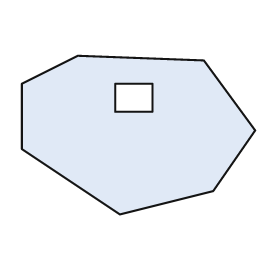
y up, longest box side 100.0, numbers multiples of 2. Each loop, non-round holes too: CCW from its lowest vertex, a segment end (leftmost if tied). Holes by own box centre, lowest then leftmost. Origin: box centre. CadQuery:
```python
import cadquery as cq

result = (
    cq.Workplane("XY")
    .moveTo(-8.0, -34.0)
    .lineTo(32.0, -24.0)
    .lineTo(50.0, 2.0)
    .lineTo(28.0, 32.0)
    .lineTo(-26.0, 34.0)
    .lineTo(-50.0, 22.0)
    .lineTo(-50.0, -6.0)
    .close()
    .moveTo(-10.0, 10.0)
    .lineTo(6.0, 10.0)
    .lineTo(6.0, 22.0)
    .lineTo(-10.0, 22.0)
    .close()
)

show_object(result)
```